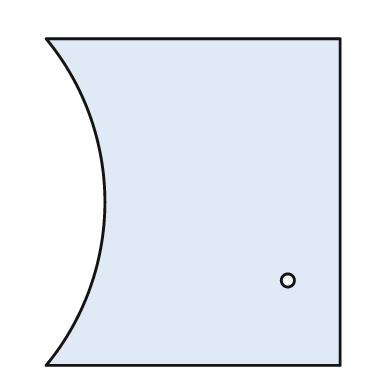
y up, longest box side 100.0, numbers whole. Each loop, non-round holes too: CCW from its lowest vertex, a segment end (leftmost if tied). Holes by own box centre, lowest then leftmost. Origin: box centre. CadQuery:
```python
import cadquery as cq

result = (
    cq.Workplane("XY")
    .moveTo(-45.0, -50.0)
    .lineTo(45.0, -50.0)
    .lineTo(45.0, 50.0)
    .lineTo(-45.0, 50.0)
    .threePointArc((-27.0, 0.0), (-45.0, -50.0))
    .close()
    .moveTo(29.0, -24.0)
    .circle(2.0)
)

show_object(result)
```